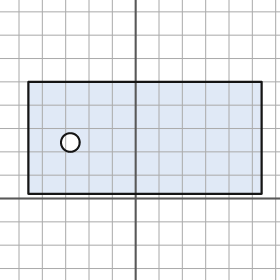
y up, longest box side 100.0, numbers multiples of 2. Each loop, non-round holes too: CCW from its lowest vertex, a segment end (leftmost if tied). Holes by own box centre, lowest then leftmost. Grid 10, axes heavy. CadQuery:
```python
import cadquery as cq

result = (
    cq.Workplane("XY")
    .moveTo(-46.0, 2.0)
    .lineTo(54.0, 2.0)
    .lineTo(54.0, 50.0)
    .lineTo(-46.0, 50.0)
    .close()
    .moveTo(-28.0, 24.0)
    .circle(4.0)
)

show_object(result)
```